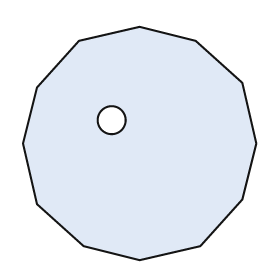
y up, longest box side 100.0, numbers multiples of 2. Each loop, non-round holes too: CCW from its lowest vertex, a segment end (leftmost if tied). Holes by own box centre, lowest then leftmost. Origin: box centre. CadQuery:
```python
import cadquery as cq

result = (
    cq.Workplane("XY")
    .moveTo(0.0, -50.0)
    .lineTo(26.0, -44.0)
    .lineTo(44.0, -24.0)
    .lineTo(50.0, 0.0)
    .lineTo(44.0, 26.0)
    .lineTo(24.0, 44.0)
    .lineTo(0.0, 50.0)
    .lineTo(-26.0, 44.0)
    .lineTo(-44.0, 24.0)
    .lineTo(-50.0, 0.0)
    .lineTo(-44.0, -26.0)
    .lineTo(-24.0, -44.0)
    .close()
    .moveTo(-12.0, 10.0)
    .circle(6.0)
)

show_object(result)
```